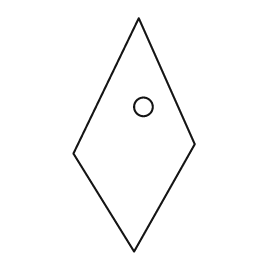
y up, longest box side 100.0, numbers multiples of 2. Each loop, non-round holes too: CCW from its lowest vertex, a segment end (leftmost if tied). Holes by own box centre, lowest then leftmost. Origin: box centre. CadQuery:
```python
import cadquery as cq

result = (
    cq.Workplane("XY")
    .moveTo(0.0, -50.0)
    .lineTo(26.0, -4.0)
    .lineTo(2.0, 50.0)
    .lineTo(-26.0, -8.0)
    .close()
    .moveTo(4.0, 12.0)
    .circle(4.0)
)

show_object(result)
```